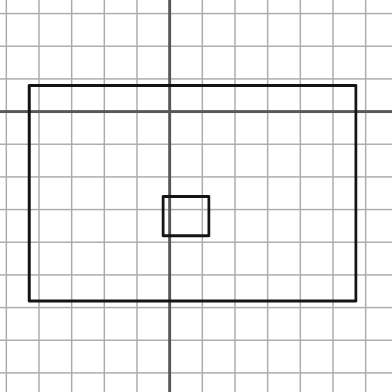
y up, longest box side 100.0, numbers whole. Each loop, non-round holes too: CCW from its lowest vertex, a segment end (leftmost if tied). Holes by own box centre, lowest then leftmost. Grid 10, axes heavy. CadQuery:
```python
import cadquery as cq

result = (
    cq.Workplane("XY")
    .moveTo(-43.0, -58.0)
    .lineTo(57.0, -58.0)
    .lineTo(57.0, 8.0)
    .lineTo(-43.0, 8.0)
    .close()
    .moveTo(-2.0, -38.0)
    .lineTo(12.0, -38.0)
    .lineTo(12.0, -26.0)
    .lineTo(-2.0, -26.0)
    .close()
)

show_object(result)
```